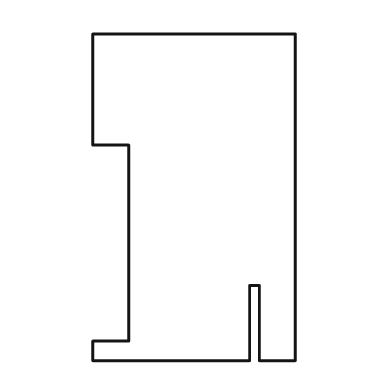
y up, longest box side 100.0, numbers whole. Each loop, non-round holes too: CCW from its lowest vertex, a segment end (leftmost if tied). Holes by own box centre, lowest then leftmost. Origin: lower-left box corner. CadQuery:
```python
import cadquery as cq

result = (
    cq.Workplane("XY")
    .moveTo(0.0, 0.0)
    .lineTo(48.0, 0.0)
    .lineTo(48.0, 23.0)
    .lineTo(51.0, 23.0)
    .lineTo(51.0, 0.0)
    .lineTo(62.0, 0.0)
    .lineTo(62.0, 100.0)
    .lineTo(0.0, 100.0)
    .lineTo(0.0, 66.0)
    .lineTo(11.0, 66.0)
    .lineTo(11.0, 6.0)
    .lineTo(0.0, 6.0)
    .close()
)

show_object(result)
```